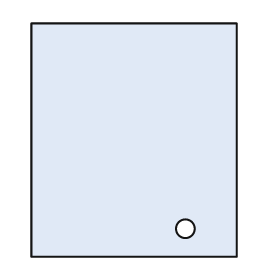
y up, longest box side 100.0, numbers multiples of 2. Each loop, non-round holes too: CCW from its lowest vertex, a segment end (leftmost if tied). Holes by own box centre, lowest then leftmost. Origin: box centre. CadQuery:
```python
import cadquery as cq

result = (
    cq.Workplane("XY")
    .moveTo(-44.0, -50.0)
    .lineTo(44.0, -50.0)
    .lineTo(44.0, 50.0)
    .lineTo(-44.0, 50.0)
    .close()
    .moveTo(22.0, -38.0)
    .circle(4.0)
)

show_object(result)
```